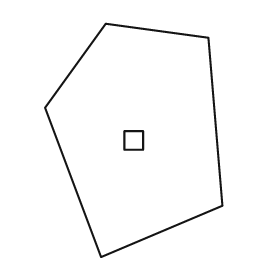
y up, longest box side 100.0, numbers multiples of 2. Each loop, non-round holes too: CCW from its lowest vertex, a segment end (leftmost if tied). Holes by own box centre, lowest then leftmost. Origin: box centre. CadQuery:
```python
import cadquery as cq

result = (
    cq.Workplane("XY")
    .moveTo(-14.0, -50.0)
    .lineTo(38.0, -28.0)
    .lineTo(32.0, 44.0)
    .lineTo(-12.0, 50.0)
    .lineTo(-38.0, 14.0)
    .close()
    .moveTo(-4.0, -4.0)
    .lineTo(4.0, -4.0)
    .lineTo(4.0, 4.0)
    .lineTo(-4.0, 4.0)
    .close()
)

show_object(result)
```